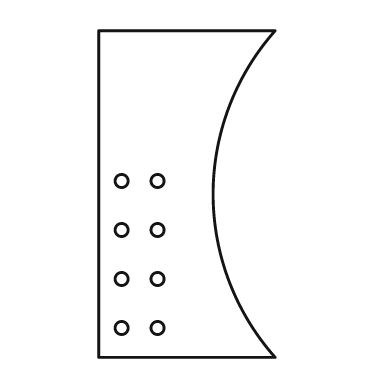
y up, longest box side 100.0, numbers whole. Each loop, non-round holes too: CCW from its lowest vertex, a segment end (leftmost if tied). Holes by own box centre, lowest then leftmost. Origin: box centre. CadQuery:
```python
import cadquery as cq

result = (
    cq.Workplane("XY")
    .moveTo(-27.0, -50.0)
    .lineTo(27.0, -50.0)
    .threePointArc((8.0, 0.0), (27.0, 50.0))
    .lineTo(-27.0, 50.0)
    .close()
    .moveTo(-20.0, -41.0)
    .circle(2.0)
    .moveTo(-9.0, -41.0)
    .circle(2.0)
    .moveTo(-20.0, -26.0)
    .circle(2.0)
    .moveTo(-9.0, -26.0)
    .circle(2.0)
    .moveTo(-20.0, -11.0)
    .circle(2.0)
    .moveTo(-9.0, -11.0)
    .circle(2.0)
    .moveTo(-20.0, 4.0)
    .circle(2.0)
    .moveTo(-9.0, 4.0)
    .circle(2.0)
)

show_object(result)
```